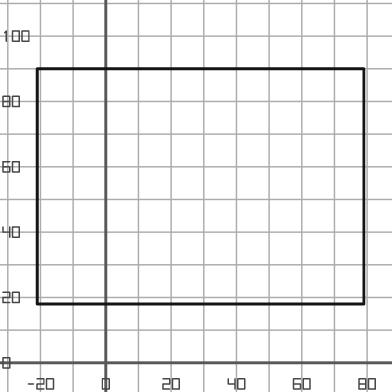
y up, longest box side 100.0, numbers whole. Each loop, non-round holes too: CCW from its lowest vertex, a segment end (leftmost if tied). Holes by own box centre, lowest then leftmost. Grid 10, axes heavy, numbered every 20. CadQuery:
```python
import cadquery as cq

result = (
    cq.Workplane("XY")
    .moveTo(-21.0, 18.0)
    .lineTo(79.0, 18.0)
    .lineTo(79.0, 90.0)
    .lineTo(-21.0, 90.0)
    .close()
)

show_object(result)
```